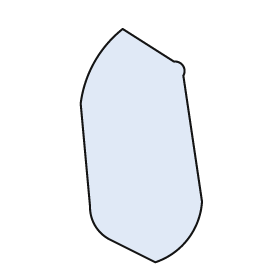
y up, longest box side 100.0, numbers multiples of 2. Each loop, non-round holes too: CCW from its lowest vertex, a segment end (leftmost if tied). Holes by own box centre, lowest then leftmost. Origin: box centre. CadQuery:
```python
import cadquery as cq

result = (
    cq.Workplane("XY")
    .moveTo(6.0, -50.0)
    .threePointArc((20.0, -40.0), (26.0, -24.0))
    .lineTo(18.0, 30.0)
    .threePointArc((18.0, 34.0), (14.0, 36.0))
    .lineTo(-8.0, 50.0)
    .threePointArc((-20.0, 36.0), (-26.0, 18.0))
    .lineTo(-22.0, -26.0)
    .threePointArc((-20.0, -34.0), (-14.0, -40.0))
    .close()
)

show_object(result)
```